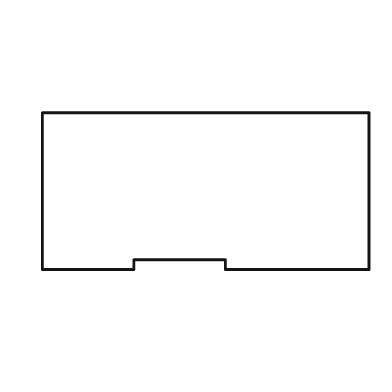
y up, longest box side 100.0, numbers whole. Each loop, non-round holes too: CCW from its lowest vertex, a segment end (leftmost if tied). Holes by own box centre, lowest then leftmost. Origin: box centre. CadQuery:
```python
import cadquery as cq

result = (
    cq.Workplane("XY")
    .moveTo(-50.0, -24.0)
    .lineTo(-22.0, -24.0)
    .lineTo(-22.0, -21.0)
    .lineTo(6.0, -21.0)
    .lineTo(6.0, -24.0)
    .lineTo(50.0, -24.0)
    .lineTo(50.0, 24.0)
    .lineTo(-50.0, 24.0)
    .close()
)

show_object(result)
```